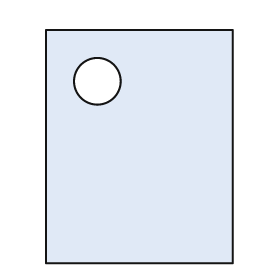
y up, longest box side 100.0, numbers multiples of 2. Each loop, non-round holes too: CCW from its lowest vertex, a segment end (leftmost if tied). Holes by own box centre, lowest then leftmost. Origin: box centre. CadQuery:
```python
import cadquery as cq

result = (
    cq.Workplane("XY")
    .moveTo(-40.0, -50.0)
    .lineTo(40.0, -50.0)
    .lineTo(40.0, 50.0)
    .lineTo(-40.0, 50.0)
    .close()
    .moveTo(-18.0, 28.0)
    .circle(10.0)
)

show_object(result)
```